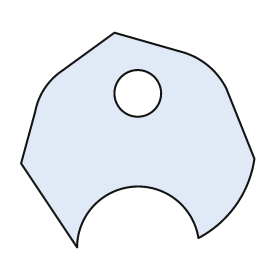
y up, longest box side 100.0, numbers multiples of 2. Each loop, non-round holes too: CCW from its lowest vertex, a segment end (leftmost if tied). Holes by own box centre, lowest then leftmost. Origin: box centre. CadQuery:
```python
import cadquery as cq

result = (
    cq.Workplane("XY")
    .moveTo(-26.0, -46.0)
    .threePointArc((-2.0, -20.0), (26.0, -42.0))
    .threePointArc((42.0, -28.0), (50.0, -8.0))
    .lineTo(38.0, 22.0)
    .threePointArc((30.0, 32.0), (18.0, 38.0))
    .lineTo(-10.0, 46.0)
    .lineTo(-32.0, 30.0)
    .threePointArc((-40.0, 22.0), (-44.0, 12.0))
    .lineTo(-50.0, -10.0)
    .close()
    .moveTo(0.0, 20.0)
    .circle(10.0)
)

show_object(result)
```